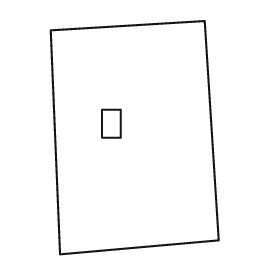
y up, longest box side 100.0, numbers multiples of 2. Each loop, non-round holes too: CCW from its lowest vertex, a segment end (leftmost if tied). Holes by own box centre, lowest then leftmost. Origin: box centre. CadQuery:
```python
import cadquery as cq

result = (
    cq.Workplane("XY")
    .moveTo(-32.0, -50.0)
    .lineTo(36.0, -44.0)
    .lineTo(30.0, 50.0)
    .lineTo(-36.0, 46.0)
    .close()
    .moveTo(-14.0, 0.0)
    .lineTo(-6.0, 0.0)
    .lineTo(-6.0, 12.0)
    .lineTo(-14.0, 12.0)
    .close()
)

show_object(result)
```